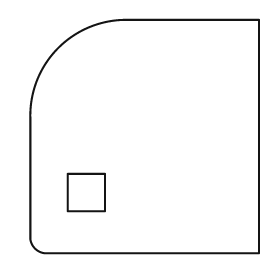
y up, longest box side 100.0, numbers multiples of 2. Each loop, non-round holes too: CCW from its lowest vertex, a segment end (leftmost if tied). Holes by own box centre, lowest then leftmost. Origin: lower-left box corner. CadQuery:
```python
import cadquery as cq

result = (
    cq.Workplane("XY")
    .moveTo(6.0, 0.0)
    .lineTo(98.0, 0.0)
    .lineTo(98.0, 100.0)
    .lineTo(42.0, 100.0)
    .threePointArc((12.0, 88.0), (0.0, 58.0))
    .lineTo(0.0, 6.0)
    .threePointArc((2.0, 2.0), (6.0, 0.0))
    .close()
    .moveTo(16.0, 18.0)
    .lineTo(32.0, 18.0)
    .lineTo(32.0, 34.0)
    .lineTo(16.0, 34.0)
    .close()
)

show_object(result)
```